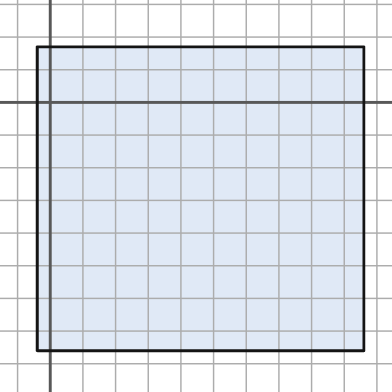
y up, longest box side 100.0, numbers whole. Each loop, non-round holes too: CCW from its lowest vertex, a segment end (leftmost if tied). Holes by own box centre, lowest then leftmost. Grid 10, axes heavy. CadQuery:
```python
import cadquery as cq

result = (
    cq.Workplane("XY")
    .moveTo(-4.0, -76.0)
    .lineTo(96.0, -76.0)
    .lineTo(96.0, 17.0)
    .lineTo(-4.0, 17.0)
    .close()
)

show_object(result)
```